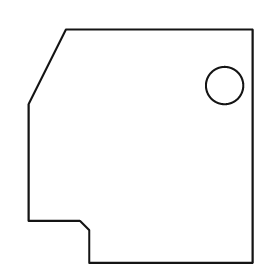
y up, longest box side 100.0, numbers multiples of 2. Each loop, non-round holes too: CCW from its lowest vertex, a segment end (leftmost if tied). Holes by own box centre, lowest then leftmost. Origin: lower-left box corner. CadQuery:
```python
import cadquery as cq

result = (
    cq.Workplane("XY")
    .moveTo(26.0, 0.0)
    .lineTo(96.0, 0.0)
    .lineTo(96.0, 100.0)
    .lineTo(16.0, 100.0)
    .lineTo(0.0, 68.0)
    .lineTo(0.0, 18.0)
    .lineTo(22.0, 18.0)
    .lineTo(26.0, 14.0)
    .close()
    .moveTo(84.0, 76.0)
    .circle(8.0)
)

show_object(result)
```